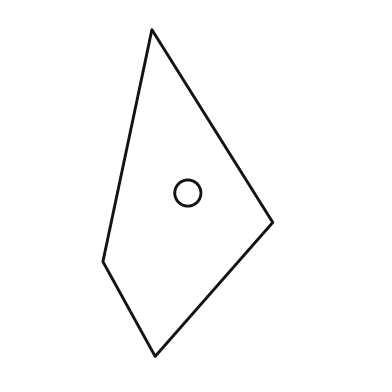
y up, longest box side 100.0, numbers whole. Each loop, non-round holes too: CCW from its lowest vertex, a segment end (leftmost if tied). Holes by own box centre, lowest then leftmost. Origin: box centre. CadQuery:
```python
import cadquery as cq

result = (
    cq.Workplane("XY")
    .moveTo(-10.0, -50.0)
    .lineTo(26.0, -9.0)
    .lineTo(-11.0, 50.0)
    .lineTo(-26.0, -21.0)
    .close()
    .moveTo(0.0, 0.0)
    .circle(4.0)
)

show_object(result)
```